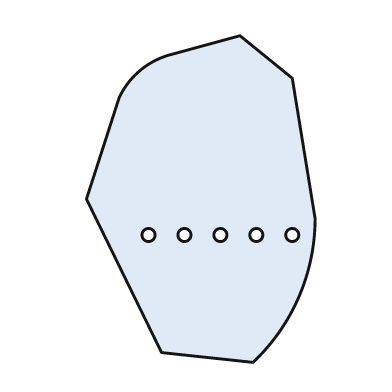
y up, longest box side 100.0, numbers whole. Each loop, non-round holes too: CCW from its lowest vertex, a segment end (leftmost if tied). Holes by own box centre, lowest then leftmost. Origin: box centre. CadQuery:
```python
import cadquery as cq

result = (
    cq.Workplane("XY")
    .moveTo(16.0, -50.0)
    .threePointArc((30.0, -30.0), (35.0, -6.0))
    .lineTo(28.0, 37.0)
    .lineTo(12.0, 50.0)
    .lineTo(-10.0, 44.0)
    .threePointArc((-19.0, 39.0), (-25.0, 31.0))
    .lineTo(-35.0, 0.0)
    .lineTo(-12.0, -47.0)
    .close()
    .moveTo(-16.0, -11.0)
    .circle(2.0)
    .moveTo(-5.0, -11.0)
    .circle(2.0)
    .moveTo(6.0, -11.0)
    .circle(2.0)
    .moveTo(17.0, -11.0)
    .circle(2.0)
    .moveTo(28.0, -11.0)
    .circle(2.0)
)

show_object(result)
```